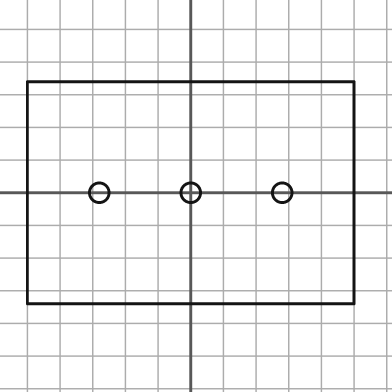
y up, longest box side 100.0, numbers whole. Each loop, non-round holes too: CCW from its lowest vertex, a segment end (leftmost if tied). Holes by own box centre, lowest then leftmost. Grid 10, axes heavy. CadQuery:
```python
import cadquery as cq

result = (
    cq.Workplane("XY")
    .moveTo(-50.0, -34.0)
    .lineTo(50.0, -34.0)
    .lineTo(50.0, 34.0)
    .lineTo(-50.0, 34.0)
    .close()
    .moveTo(-28.0, 0.0)
    .circle(3.0)
    .moveTo(0.0, 0.0)
    .circle(3.0)
    .moveTo(28.0, 0.0)
    .circle(3.0)
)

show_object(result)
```